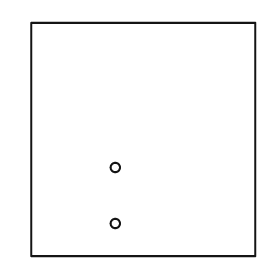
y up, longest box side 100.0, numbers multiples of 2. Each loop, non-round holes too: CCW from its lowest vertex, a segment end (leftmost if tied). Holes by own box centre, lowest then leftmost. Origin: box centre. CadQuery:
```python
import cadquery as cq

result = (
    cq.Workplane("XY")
    .moveTo(-48.0, -50.0)
    .lineTo(48.0, -50.0)
    .lineTo(48.0, 50.0)
    .lineTo(-48.0, 50.0)
    .close()
    .moveTo(-12.0, -36.0)
    .circle(2.0)
    .moveTo(-12.0, -12.0)
    .circle(2.0)
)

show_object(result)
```